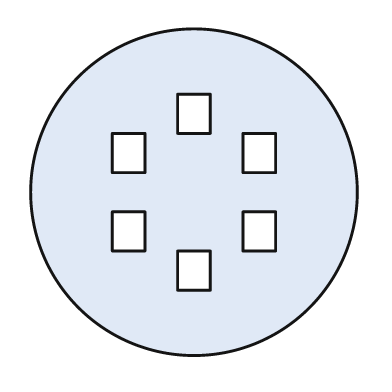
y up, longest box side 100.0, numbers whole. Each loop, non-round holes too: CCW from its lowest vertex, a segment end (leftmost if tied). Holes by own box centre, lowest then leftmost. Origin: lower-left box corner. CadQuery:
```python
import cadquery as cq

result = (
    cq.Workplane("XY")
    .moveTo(50.0, 50.0)
    .circle(50.0)
    .moveTo(45.0, 20.0)
    .lineTo(55.0, 20.0)
    .lineTo(55.0, 32.0)
    .lineTo(45.0, 32.0)
    .close()
    .moveTo(25.0, 32.0)
    .lineTo(35.0, 32.0)
    .lineTo(35.0, 44.0)
    .lineTo(25.0, 44.0)
    .close()
    .moveTo(65.0, 32.0)
    .lineTo(75.0, 32.0)
    .lineTo(75.0, 44.0)
    .lineTo(65.0, 44.0)
    .close()
    .moveTo(25.0, 56.0)
    .lineTo(35.0, 56.0)
    .lineTo(35.0, 68.0)
    .lineTo(25.0, 68.0)
    .close()
    .moveTo(65.0, 56.0)
    .lineTo(75.0, 56.0)
    .lineTo(75.0, 68.0)
    .lineTo(65.0, 68.0)
    .close()
    .moveTo(45.0, 68.0)
    .lineTo(55.0, 68.0)
    .lineTo(55.0, 80.0)
    .lineTo(45.0, 80.0)
    .close()
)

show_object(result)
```